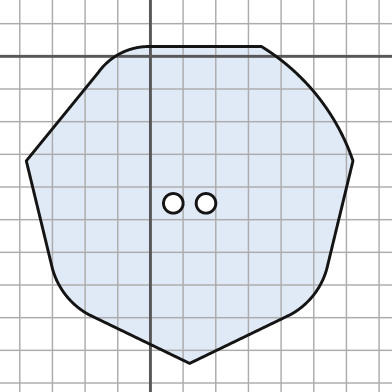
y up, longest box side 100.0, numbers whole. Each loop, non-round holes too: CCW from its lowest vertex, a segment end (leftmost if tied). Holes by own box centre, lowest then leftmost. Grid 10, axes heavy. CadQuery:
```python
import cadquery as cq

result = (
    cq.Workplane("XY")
    .moveTo(12.0, -94.0)
    .lineTo(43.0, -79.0)
    .threePointArc((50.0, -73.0), (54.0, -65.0))
    .lineTo(62.0, -32.0)
    .threePointArc((51.0, -12.0), (34.0, 3.0))
    .lineTo(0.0, 3.0)
    .threePointArc((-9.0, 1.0), (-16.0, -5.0))
    .lineTo(-38.0, -32.0)
    .lineTo(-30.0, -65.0)
    .threePointArc((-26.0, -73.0), (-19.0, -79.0))
    .close()
    .moveTo(7.0, -45.0)
    .circle(3.0)
    .moveTo(17.0, -45.0)
    .circle(3.0)
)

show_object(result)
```